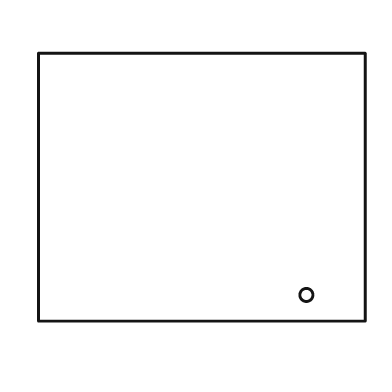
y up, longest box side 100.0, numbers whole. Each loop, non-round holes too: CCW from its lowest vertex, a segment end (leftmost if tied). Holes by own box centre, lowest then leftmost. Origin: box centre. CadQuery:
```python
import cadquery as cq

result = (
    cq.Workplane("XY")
    .moveTo(-50.0, -41.0)
    .lineTo(50.0, -41.0)
    .lineTo(50.0, 41.0)
    .lineTo(-50.0, 41.0)
    .close()
    .moveTo(32.0, -33.0)
    .circle(2.0)
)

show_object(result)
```